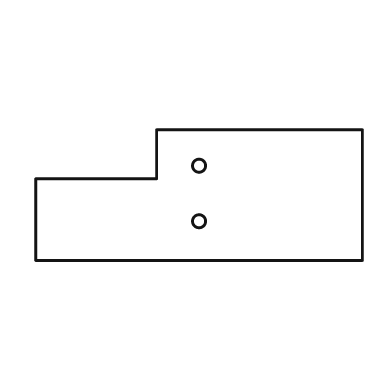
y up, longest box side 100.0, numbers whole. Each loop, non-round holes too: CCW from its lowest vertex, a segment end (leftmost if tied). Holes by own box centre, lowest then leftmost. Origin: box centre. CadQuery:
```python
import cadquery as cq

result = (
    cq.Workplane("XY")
    .moveTo(-50.0, -20.0)
    .lineTo(50.0, -20.0)
    .lineTo(50.0, 20.0)
    .lineTo(-13.0, 20.0)
    .lineTo(-13.0, 5.0)
    .lineTo(-50.0, 5.0)
    .close()
    .moveTo(0.0, -8.0)
    .circle(2.0)
    .moveTo(0.0, 9.0)
    .circle(2.0)
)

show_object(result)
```